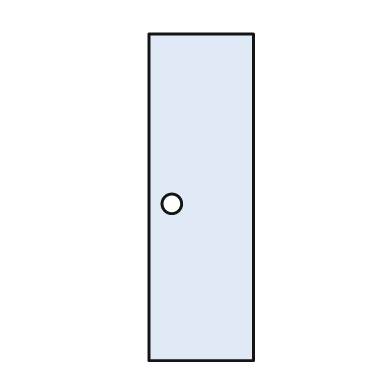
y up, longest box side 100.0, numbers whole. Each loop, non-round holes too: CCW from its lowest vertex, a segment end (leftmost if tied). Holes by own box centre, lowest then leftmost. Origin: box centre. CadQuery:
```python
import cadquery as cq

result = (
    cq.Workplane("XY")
    .moveTo(-16.0, -50.0)
    .lineTo(16.0, -50.0)
    .lineTo(16.0, 50.0)
    .lineTo(-16.0, 50.0)
    .close()
    .moveTo(-9.0, -2.0)
    .circle(3.0)
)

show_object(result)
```